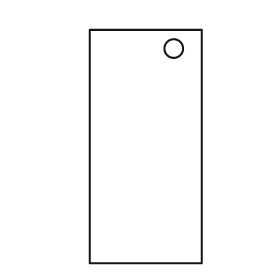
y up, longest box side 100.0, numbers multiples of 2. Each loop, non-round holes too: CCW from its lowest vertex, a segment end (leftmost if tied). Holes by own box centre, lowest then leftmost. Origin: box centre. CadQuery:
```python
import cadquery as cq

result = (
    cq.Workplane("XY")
    .moveTo(-24.0, -50.0)
    .lineTo(24.0, -50.0)
    .lineTo(24.0, 50.0)
    .lineTo(-24.0, 50.0)
    .close()
    .moveTo(12.0, 42.0)
    .circle(4.0)
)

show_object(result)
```